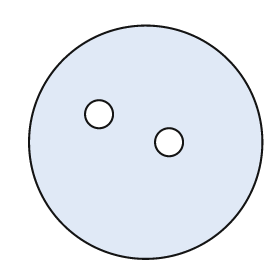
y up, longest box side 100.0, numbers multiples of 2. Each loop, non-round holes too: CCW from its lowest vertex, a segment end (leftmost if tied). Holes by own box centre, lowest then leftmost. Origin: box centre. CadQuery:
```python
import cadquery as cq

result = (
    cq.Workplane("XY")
    .moveTo(0.0, 0.0)
    .circle(50.0)
    .moveTo(10.0, 0.0)
    .circle(6.0)
    .moveTo(-20.0, 12.0)
    .circle(6.0)
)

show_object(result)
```